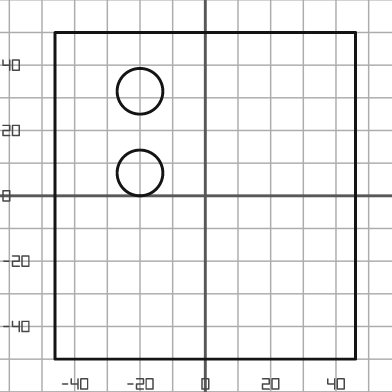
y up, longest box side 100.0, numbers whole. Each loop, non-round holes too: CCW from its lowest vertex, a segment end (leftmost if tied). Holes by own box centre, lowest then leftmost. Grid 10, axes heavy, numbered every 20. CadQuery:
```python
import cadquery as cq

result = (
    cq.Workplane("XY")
    .moveTo(-46.0, -50.0)
    .lineTo(46.0, -50.0)
    .lineTo(46.0, 50.0)
    .lineTo(-46.0, 50.0)
    .close()
    .moveTo(-20.0, 7.0)
    .circle(7.0)
    .moveTo(-20.0, 32.0)
    .circle(7.0)
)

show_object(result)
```